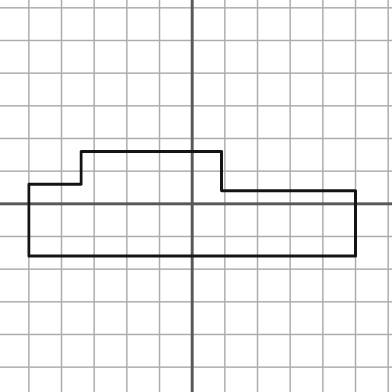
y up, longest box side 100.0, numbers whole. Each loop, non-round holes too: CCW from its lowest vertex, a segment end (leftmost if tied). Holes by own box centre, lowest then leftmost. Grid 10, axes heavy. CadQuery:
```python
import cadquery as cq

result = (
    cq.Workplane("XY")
    .moveTo(-50.0, -16.0)
    .lineTo(50.0, -16.0)
    .lineTo(50.0, 4.0)
    .lineTo(9.0, 4.0)
    .lineTo(9.0, 16.0)
    .lineTo(-34.0, 16.0)
    .lineTo(-34.0, 6.0)
    .lineTo(-50.0, 6.0)
    .close()
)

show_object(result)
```